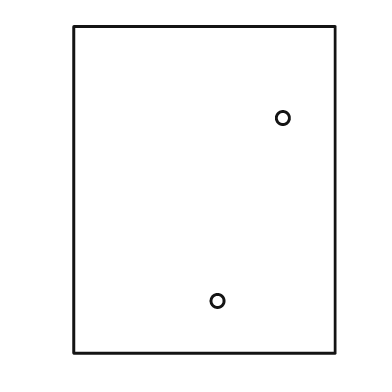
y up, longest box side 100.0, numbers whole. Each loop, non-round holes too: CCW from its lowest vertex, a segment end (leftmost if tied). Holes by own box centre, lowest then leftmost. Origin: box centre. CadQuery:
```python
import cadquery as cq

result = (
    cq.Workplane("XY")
    .moveTo(-40.0, -50.0)
    .lineTo(40.0, -50.0)
    .lineTo(40.0, 50.0)
    .lineTo(-40.0, 50.0)
    .close()
    .moveTo(4.0, -34.0)
    .circle(2.0)
    .moveTo(24.0, 22.0)
    .circle(2.0)
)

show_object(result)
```